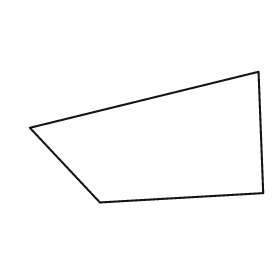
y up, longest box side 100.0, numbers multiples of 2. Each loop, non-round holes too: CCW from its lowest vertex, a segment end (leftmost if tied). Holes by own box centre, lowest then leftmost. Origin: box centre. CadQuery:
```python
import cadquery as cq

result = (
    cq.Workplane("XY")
    .moveTo(-20.0, -28.0)
    .lineTo(50.0, -24.0)
    .lineTo(48.0, 28.0)
    .lineTo(-50.0, 4.0)
    .close()
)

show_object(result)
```